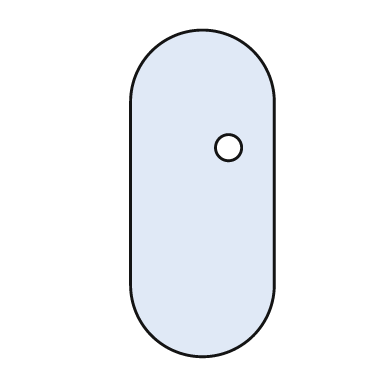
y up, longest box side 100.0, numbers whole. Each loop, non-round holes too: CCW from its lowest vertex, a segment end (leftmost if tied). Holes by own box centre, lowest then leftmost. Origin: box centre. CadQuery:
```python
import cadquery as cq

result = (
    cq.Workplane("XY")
    .moveTo(-22.0, -28.0)
    .threePointArc((0.0, -50.0), (22.0, -28.0))
    .lineTo(22.0, 28.0)
    .threePointArc((0.0, 50.0), (-22.0, 28.0))
    .close()
    .moveTo(8.0, 14.0)
    .circle(4.0)
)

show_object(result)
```